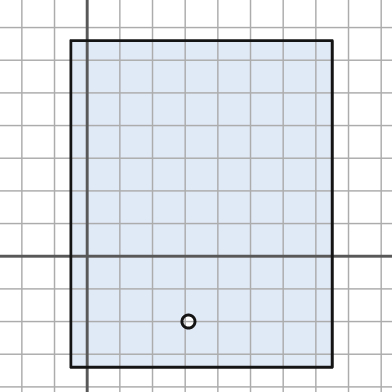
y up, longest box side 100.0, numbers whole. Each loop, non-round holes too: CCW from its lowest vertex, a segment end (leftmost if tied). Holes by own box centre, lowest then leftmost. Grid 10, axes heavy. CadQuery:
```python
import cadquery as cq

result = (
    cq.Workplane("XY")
    .moveTo(-5.0, -34.0)
    .lineTo(75.0, -34.0)
    .lineTo(75.0, 66.0)
    .lineTo(-5.0, 66.0)
    .close()
    .moveTo(31.0, -20.0)
    .circle(2.0)
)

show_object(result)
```